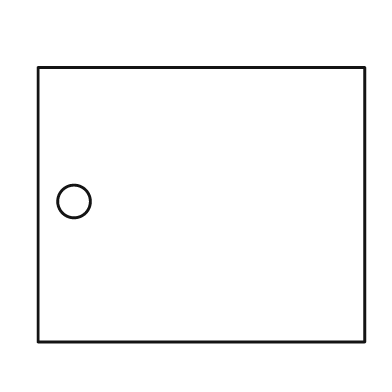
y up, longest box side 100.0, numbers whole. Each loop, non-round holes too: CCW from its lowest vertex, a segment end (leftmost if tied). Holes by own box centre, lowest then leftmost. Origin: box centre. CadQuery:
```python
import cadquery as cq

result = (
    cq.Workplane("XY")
    .moveTo(-50.0, -42.0)
    .lineTo(50.0, -42.0)
    .lineTo(50.0, 42.0)
    .lineTo(-50.0, 42.0)
    .close()
    .moveTo(-39.0, 1.0)
    .circle(5.0)
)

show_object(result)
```